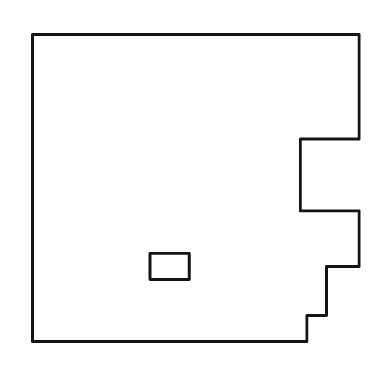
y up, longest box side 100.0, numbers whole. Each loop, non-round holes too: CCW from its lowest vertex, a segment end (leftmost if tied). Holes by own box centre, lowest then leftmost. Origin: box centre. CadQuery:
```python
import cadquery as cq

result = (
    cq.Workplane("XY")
    .moveTo(-50.0, -47.0)
    .lineTo(34.0, -47.0)
    .lineTo(34.0, -39.0)
    .lineTo(40.0, -39.0)
    .lineTo(40.0, -24.0)
    .lineTo(50.0, -24.0)
    .lineTo(50.0, -7.0)
    .lineTo(32.0, -7.0)
    .lineTo(32.0, 15.0)
    .lineTo(50.0, 15.0)
    .lineTo(50.0, 47.0)
    .lineTo(-50.0, 47.0)
    .close()
    .moveTo(-14.0, -28.0)
    .lineTo(-2.0, -28.0)
    .lineTo(-2.0, -20.0)
    .lineTo(-14.0, -20.0)
    .close()
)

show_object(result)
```